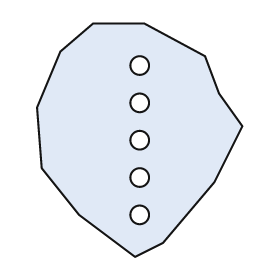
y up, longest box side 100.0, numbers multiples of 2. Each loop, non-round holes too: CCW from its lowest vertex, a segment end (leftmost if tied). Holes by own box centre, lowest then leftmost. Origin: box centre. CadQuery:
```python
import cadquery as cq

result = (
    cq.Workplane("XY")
    .moveTo(-2.0, -50.0)
    .lineTo(10.0, -44.0)
    .lineTo(32.0, -18.0)
    .lineTo(44.0, 6.0)
    .lineTo(34.0, 20.0)
    .lineTo(28.0, 36.0)
    .lineTo(2.0, 50.0)
    .lineTo(-20.0, 50.0)
    .lineTo(-34.0, 38.0)
    .lineTo(-44.0, 14.0)
    .lineTo(-42.0, -12.0)
    .lineTo(-26.0, -32.0)
    .close()
    .moveTo(0.0, -32.0)
    .circle(4.0)
    .moveTo(0.0, -16.0)
    .circle(4.0)
    .moveTo(0.0, 0.0)
    .circle(4.0)
    .moveTo(0.0, 16.0)
    .circle(4.0)
    .moveTo(0.0, 32.0)
    .circle(4.0)
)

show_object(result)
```